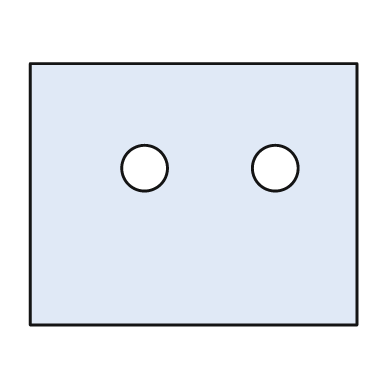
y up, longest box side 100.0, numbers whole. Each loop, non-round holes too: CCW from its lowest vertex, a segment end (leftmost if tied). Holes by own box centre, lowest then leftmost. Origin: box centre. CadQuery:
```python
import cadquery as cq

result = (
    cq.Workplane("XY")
    .moveTo(-50.0, -40.0)
    .lineTo(50.0, -40.0)
    .lineTo(50.0, 40.0)
    .lineTo(-50.0, 40.0)
    .close()
    .moveTo(-15.0, 8.0)
    .circle(7.0)
    .moveTo(25.0, 8.0)
    .circle(7.0)
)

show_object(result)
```